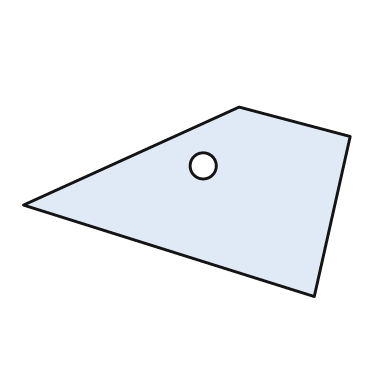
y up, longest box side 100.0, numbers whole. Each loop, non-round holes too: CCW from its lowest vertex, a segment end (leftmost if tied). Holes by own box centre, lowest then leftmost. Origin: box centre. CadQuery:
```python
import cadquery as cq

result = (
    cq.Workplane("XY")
    .moveTo(39.0, -29.0)
    .lineTo(50.0, 20.0)
    .lineTo(16.0, 29.0)
    .lineTo(-50.0, -1.0)
    .close()
    .moveTo(5.0, 11.0)
    .circle(4.0)
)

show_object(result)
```